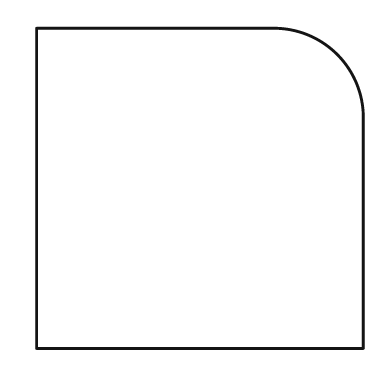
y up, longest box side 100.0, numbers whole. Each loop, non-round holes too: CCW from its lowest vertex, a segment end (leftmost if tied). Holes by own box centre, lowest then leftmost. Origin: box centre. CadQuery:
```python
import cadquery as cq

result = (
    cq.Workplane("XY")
    .moveTo(-50.0, -49.0)
    .lineTo(50.0, -49.0)
    .lineTo(50.0, 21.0)
    .threePointArc((42.0, 41.0), (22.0, 49.0))
    .lineTo(-50.0, 49.0)
    .close()
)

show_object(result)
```